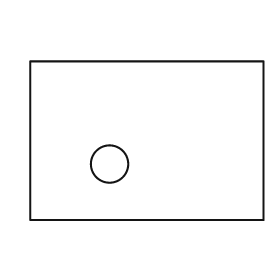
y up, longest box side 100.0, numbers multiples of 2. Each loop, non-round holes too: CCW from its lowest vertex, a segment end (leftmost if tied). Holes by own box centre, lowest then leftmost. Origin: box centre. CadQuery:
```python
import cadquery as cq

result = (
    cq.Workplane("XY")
    .moveTo(-50.0, -34.0)
    .lineTo(50.0, -34.0)
    .lineTo(50.0, 34.0)
    .lineTo(-50.0, 34.0)
    .close()
    .moveTo(-16.0, -10.0)
    .circle(8.0)
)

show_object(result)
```